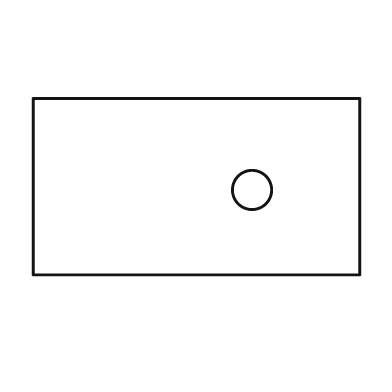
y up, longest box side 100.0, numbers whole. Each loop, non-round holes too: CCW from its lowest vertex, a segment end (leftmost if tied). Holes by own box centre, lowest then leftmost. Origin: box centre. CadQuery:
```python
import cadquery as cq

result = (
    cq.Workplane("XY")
    .moveTo(-50.0, -27.0)
    .lineTo(50.0, -27.0)
    .lineTo(50.0, 27.0)
    .lineTo(-50.0, 27.0)
    .close()
    .moveTo(17.0, -1.0)
    .circle(6.0)
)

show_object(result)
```